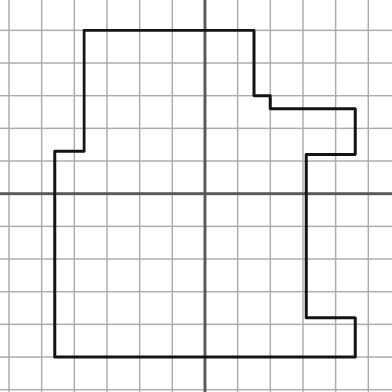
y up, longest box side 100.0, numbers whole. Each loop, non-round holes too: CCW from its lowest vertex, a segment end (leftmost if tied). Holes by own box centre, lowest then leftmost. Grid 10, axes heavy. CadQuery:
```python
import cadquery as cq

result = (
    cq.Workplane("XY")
    .moveTo(-46.0, -50.0)
    .lineTo(46.0, -50.0)
    .lineTo(46.0, -38.0)
    .lineTo(31.0, -38.0)
    .lineTo(31.0, 12.0)
    .lineTo(46.0, 12.0)
    .lineTo(46.0, 26.0)
    .lineTo(20.0, 26.0)
    .lineTo(20.0, 30.0)
    .lineTo(15.0, 30.0)
    .lineTo(15.0, 50.0)
    .lineTo(-37.0, 50.0)
    .lineTo(-37.0, 13.0)
    .lineTo(-46.0, 13.0)
    .close()
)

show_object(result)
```